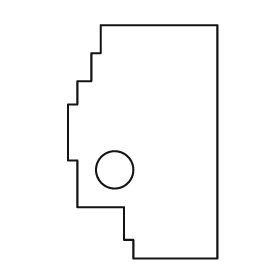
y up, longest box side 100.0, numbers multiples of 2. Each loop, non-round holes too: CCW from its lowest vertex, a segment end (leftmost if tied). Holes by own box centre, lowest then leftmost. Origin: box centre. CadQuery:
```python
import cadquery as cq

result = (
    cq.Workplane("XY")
    .moveTo(-4.0, -50.0)
    .lineTo(32.0, -50.0)
    .lineTo(32.0, 50.0)
    .lineTo(-18.0, 50.0)
    .lineTo(-18.0, 38.0)
    .lineTo(-22.0, 38.0)
    .lineTo(-22.0, 26.0)
    .lineTo(-28.0, 26.0)
    .lineTo(-28.0, 16.0)
    .lineTo(-32.0, 16.0)
    .lineTo(-32.0, -8.0)
    .lineTo(-28.0, -8.0)
    .lineTo(-28.0, -28.0)
    .lineTo(-8.0, -28.0)
    .lineTo(-8.0, -42.0)
    .lineTo(-4.0, -42.0)
    .close()
    .moveTo(-12.0, -12.0)
    .circle(8.0)
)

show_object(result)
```